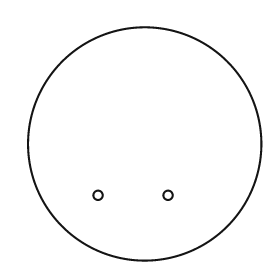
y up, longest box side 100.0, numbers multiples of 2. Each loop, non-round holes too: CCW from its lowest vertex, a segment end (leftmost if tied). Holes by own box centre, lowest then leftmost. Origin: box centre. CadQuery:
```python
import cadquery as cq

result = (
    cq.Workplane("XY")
    .moveTo(0.0, 0.0)
    .circle(50.0)
    .moveTo(-20.0, -22.0)
    .circle(2.0)
    .moveTo(10.0, -22.0)
    .circle(2.0)
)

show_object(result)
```